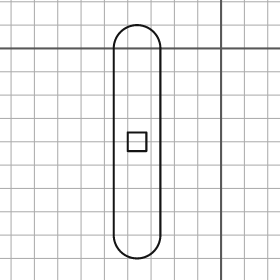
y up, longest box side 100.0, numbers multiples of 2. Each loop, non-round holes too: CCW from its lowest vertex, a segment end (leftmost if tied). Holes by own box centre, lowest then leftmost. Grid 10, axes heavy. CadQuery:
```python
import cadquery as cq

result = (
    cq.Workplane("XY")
    .moveTo(-46.0, -80.0)
    .threePointArc((-36.0, -90.0), (-26.0, -80.0))
    .lineTo(-26.0, 0.0)
    .threePointArc((-36.0, 10.0), (-46.0, 0.0))
    .close()
    .moveTo(-40.0, -44.0)
    .lineTo(-32.0, -44.0)
    .lineTo(-32.0, -36.0)
    .lineTo(-40.0, -36.0)
    .close()
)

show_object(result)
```